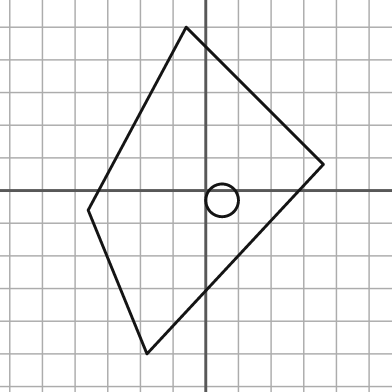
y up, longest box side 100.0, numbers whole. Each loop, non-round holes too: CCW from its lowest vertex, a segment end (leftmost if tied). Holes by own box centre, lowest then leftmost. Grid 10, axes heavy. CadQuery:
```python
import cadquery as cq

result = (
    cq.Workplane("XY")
    .moveTo(-18.0, -50.0)
    .lineTo(36.0, 8.0)
    .lineTo(-6.0, 50.0)
    .lineTo(-36.0, -6.0)
    .close()
    .moveTo(5.0, -3.0)
    .circle(5.0)
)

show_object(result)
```